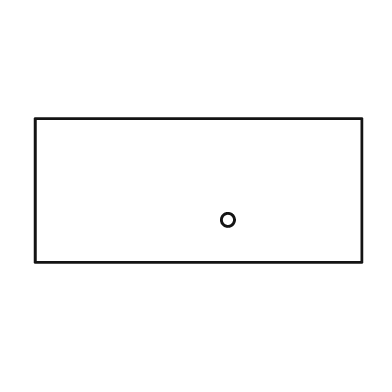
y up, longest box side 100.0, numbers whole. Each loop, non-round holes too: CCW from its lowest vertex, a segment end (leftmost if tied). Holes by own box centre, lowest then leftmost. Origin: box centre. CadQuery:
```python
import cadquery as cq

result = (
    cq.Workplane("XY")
    .moveTo(-50.0, -22.0)
    .lineTo(50.0, -22.0)
    .lineTo(50.0, 22.0)
    .lineTo(-50.0, 22.0)
    .close()
    .moveTo(9.0, -9.0)
    .circle(2.0)
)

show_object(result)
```